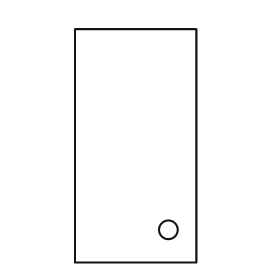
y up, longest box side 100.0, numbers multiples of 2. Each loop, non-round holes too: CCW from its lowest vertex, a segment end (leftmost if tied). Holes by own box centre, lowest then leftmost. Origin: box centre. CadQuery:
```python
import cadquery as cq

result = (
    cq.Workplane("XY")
    .moveTo(-26.0, -50.0)
    .lineTo(26.0, -50.0)
    .lineTo(26.0, 50.0)
    .lineTo(-26.0, 50.0)
    .close()
    .moveTo(14.0, -36.0)
    .circle(4.0)
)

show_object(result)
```